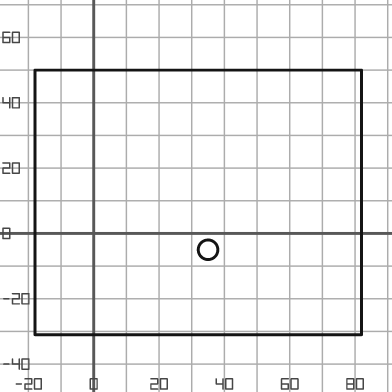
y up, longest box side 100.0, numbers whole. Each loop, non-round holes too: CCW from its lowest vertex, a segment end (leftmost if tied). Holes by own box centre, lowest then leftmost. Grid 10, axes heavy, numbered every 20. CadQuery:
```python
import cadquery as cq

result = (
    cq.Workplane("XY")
    .moveTo(-18.0, -31.0)
    .lineTo(82.0, -31.0)
    .lineTo(82.0, 50.0)
    .lineTo(-18.0, 50.0)
    .close()
    .moveTo(35.0, -5.0)
    .circle(3.0)
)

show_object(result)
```